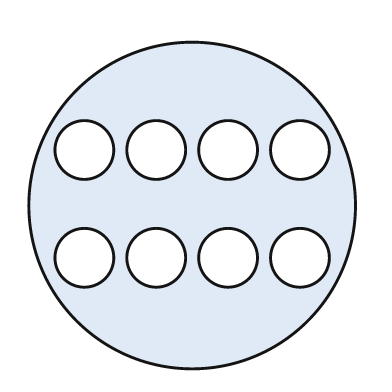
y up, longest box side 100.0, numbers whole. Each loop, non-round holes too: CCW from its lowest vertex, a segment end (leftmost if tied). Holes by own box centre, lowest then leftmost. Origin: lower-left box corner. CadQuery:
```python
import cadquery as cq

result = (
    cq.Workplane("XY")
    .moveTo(50.0, 50.0)
    .circle(50.0)
    .moveTo(17.0, 34.0)
    .circle(9.0)
    .moveTo(39.0, 34.0)
    .circle(9.0)
    .moveTo(61.0, 34.0)
    .circle(9.0)
    .moveTo(83.0, 34.0)
    .circle(9.0)
    .moveTo(17.0, 67.0)
    .circle(9.0)
    .moveTo(39.0, 67.0)
    .circle(9.0)
    .moveTo(61.0, 67.0)
    .circle(9.0)
    .moveTo(83.0, 67.0)
    .circle(9.0)
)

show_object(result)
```